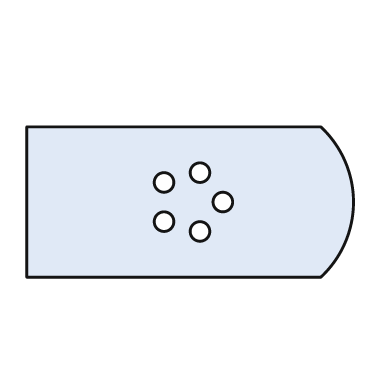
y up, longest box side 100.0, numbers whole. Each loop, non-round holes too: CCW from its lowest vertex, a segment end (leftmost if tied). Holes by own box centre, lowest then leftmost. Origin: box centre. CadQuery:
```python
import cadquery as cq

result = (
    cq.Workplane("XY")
    .moveTo(-50.0, -23.0)
    .lineTo(40.0, -23.0)
    .threePointArc((50.0, 0.0), (40.0, 23.0))
    .lineTo(-50.0, 23.0)
    .close()
    .moveTo(3.0, -9.0)
    .circle(3.0)
    .moveTo(-8.0, -6.0)
    .circle(3.0)
    .moveTo(10.0, 0.0)
    .circle(3.0)
    .moveTo(-8.0, 6.0)
    .circle(3.0)
    .moveTo(3.0, 9.0)
    .circle(3.0)
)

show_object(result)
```